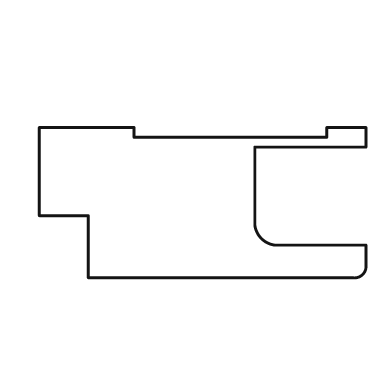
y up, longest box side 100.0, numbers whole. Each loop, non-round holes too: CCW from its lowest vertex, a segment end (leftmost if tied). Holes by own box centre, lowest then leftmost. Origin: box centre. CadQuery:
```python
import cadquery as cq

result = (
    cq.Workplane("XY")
    .moveTo(-35.0, -23.0)
    .lineTo(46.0, -23.0)
    .threePointArc((49.0, -22.0), (50.0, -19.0))
    .lineTo(50.0, -13.0)
    .lineTo(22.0, -13.0)
    .threePointArc((18.0, -11.0), (16.0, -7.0))
    .lineTo(16.0, 17.0)
    .lineTo(50.0, 17.0)
    .lineTo(50.0, 23.0)
    .lineTo(38.0, 23.0)
    .lineTo(38.0, 20.0)
    .lineTo(-21.0, 20.0)
    .lineTo(-21.0, 23.0)
    .lineTo(-50.0, 23.0)
    .lineTo(-50.0, -4.0)
    .lineTo(-35.0, -4.0)
    .close()
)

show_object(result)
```